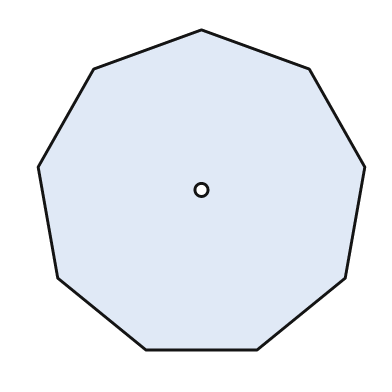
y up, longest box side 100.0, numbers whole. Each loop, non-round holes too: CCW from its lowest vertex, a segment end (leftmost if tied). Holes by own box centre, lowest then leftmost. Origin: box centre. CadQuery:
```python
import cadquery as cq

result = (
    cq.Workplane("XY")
    .moveTo(-17.0, -49.0)
    .lineTo(17.0, -49.0)
    .lineTo(44.0, -27.0)
    .lineTo(50.0, 7.0)
    .lineTo(33.0, 37.0)
    .lineTo(0.0, 49.0)
    .lineTo(-33.0, 37.0)
    .lineTo(-50.0, 7.0)
    .lineTo(-44.0, -27.0)
    .close()
    .moveTo(0.0, 0.0)
    .circle(2.0)
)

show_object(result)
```